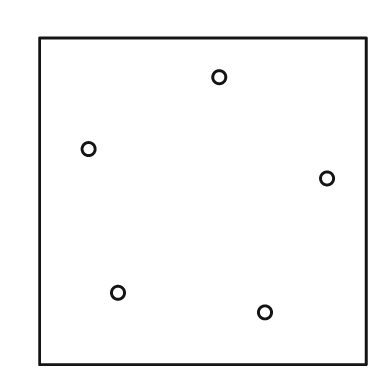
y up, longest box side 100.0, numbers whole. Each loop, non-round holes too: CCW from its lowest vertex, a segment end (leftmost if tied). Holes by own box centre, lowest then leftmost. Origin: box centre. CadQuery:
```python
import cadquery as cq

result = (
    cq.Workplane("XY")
    .moveTo(-50.0, -50.0)
    .lineTo(50.0, -50.0)
    .lineTo(50.0, 50.0)
    .lineTo(-50.0, 50.0)
    .close()
    .moveTo(19.0, -34.0)
    .circle(2.0)
    .moveTo(-26.0, -28.0)
    .circle(2.0)
    .moveTo(38.0, 7.0)
    .circle(2.0)
    .moveTo(-35.0, 16.0)
    .circle(2.0)
    .moveTo(5.0, 38.0)
    .circle(2.0)
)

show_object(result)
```